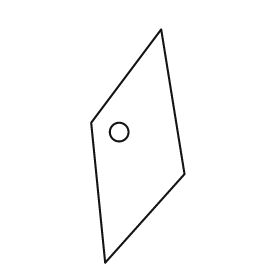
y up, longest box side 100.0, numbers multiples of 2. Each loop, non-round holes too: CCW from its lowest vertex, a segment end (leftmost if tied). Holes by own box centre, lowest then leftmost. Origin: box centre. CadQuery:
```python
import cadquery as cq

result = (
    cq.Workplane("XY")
    .moveTo(-14.0, -50.0)
    .lineTo(20.0, -12.0)
    .lineTo(10.0, 50.0)
    .lineTo(-20.0, 10.0)
    .close()
    .moveTo(-8.0, 6.0)
    .circle(4.0)
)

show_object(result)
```